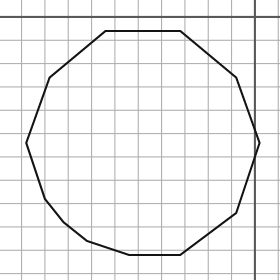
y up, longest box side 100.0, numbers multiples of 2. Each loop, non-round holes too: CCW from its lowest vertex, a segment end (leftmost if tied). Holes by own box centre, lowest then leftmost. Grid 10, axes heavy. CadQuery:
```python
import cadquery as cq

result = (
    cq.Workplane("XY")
    .moveTo(-54.0, -102.0)
    .lineTo(-32.0, -102.0)
    .lineTo(-8.0, -84.0)
    .lineTo(2.0, -54.0)
    .lineTo(-8.0, -26.0)
    .lineTo(-32.0, -6.0)
    .lineTo(-64.0, -6.0)
    .lineTo(-88.0, -26.0)
    .lineTo(-98.0, -54.0)
    .lineTo(-90.0, -78.0)
    .lineTo(-82.0, -88.0)
    .lineTo(-72.0, -96.0)
    .close()
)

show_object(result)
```